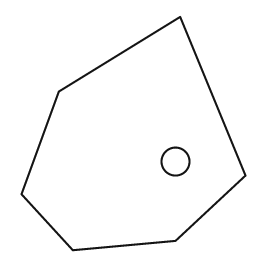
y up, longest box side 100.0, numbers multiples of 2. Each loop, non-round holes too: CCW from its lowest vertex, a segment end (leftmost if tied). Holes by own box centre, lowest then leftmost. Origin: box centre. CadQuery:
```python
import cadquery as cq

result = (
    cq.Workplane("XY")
    .moveTo(-26.0, -50.0)
    .lineTo(18.0, -46.0)
    .lineTo(48.0, -18.0)
    .lineTo(20.0, 50.0)
    .lineTo(-32.0, 18.0)
    .lineTo(-48.0, -26.0)
    .close()
    .moveTo(18.0, -12.0)
    .circle(6.0)
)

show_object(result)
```